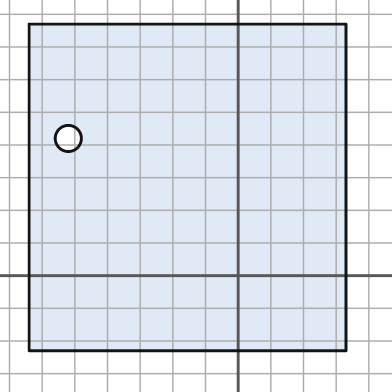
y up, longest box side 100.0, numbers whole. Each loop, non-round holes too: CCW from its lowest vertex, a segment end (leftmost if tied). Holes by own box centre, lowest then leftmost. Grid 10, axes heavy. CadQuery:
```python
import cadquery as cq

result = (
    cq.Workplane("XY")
    .moveTo(-64.0, -23.0)
    .lineTo(33.0, -23.0)
    .lineTo(33.0, 77.0)
    .lineTo(-64.0, 77.0)
    .close()
    .moveTo(-52.0, 42.0)
    .circle(4.0)
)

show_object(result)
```